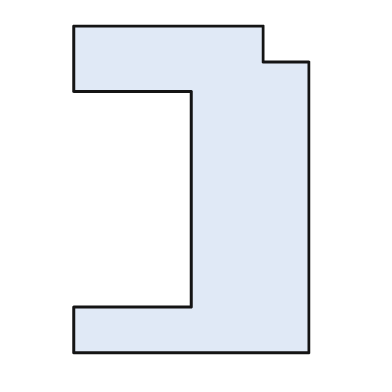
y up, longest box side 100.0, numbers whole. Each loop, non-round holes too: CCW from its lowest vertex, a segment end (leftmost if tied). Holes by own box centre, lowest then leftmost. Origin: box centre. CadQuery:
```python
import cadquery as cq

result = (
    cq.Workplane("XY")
    .moveTo(-36.0, -50.0)
    .lineTo(36.0, -50.0)
    .lineTo(36.0, 39.0)
    .lineTo(22.0, 39.0)
    .lineTo(22.0, 50.0)
    .lineTo(-36.0, 50.0)
    .lineTo(-36.0, 30.0)
    .lineTo(0.0, 30.0)
    .lineTo(0.0, -36.0)
    .lineTo(-36.0, -36.0)
    .close()
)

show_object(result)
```